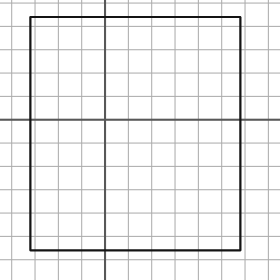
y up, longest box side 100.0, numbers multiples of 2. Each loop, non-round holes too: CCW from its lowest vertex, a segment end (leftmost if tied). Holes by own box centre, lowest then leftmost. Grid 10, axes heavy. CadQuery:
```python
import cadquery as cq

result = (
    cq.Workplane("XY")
    .moveTo(-32.0, -56.0)
    .lineTo(58.0, -56.0)
    .lineTo(58.0, 44.0)
    .lineTo(-32.0, 44.0)
    .close()
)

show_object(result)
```